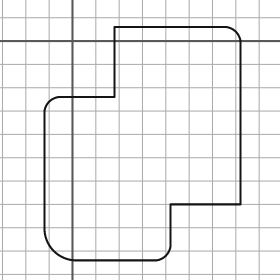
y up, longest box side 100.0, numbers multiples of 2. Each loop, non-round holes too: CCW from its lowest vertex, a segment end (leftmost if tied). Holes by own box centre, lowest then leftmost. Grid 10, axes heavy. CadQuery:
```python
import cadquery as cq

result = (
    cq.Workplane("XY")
    .moveTo(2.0, -94.0)
    .lineTo(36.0, -94.0)
    .threePointArc((40.0, -92.0), (42.0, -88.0))
    .lineTo(42.0, -70.0)
    .lineTo(72.0, -70.0)
    .lineTo(72.0, 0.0)
    .threePointArc((70.0, 4.0), (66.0, 6.0))
    .lineTo(18.0, 6.0)
    .lineTo(18.0, -24.0)
    .lineTo(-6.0, -24.0)
    .threePointArc((-10.0, -26.0), (-12.0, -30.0))
    .lineTo(-12.0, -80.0)
    .threePointArc((-8.0, -90.0), (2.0, -94.0))
    .close()
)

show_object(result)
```